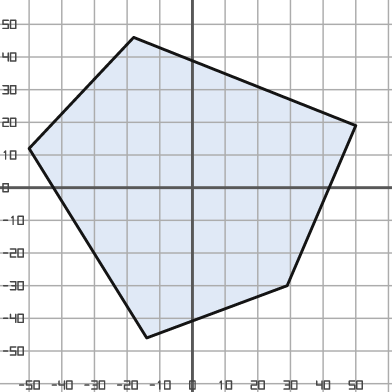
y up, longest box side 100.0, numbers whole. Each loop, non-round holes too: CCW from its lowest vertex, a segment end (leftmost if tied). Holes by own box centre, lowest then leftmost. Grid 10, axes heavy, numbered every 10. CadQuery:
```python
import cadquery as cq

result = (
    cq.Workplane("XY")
    .moveTo(-14.0, -46.0)
    .lineTo(29.0, -30.0)
    .lineTo(50.0, 19.0)
    .lineTo(-18.0, 46.0)
    .lineTo(-50.0, 12.0)
    .close()
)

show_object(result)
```